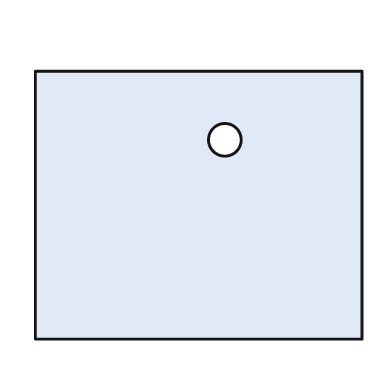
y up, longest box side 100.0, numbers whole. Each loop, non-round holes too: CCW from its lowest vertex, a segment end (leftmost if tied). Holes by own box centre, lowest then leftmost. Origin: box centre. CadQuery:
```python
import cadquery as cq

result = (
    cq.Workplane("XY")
    .moveTo(-50.0, -41.0)
    .lineTo(50.0, -41.0)
    .lineTo(50.0, 41.0)
    .lineTo(-50.0, 41.0)
    .close()
    .moveTo(8.0, 20.0)
    .circle(5.0)
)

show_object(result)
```